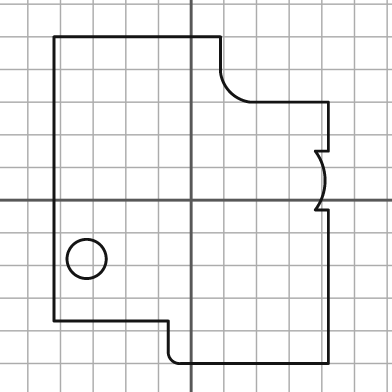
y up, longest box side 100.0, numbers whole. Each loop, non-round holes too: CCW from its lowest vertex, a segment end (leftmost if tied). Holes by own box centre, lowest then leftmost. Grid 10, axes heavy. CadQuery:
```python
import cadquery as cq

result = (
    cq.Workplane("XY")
    .moveTo(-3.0, -50.0)
    .lineTo(42.0, -50.0)
    .lineTo(42.0, -3.0)
    .lineTo(38.0, -3.0)
    .threePointArc((41.0, 6.0), (38.0, 15.0))
    .lineTo(42.0, 15.0)
    .lineTo(42.0, 30.0)
    .lineTo(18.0, 30.0)
    .threePointArc((12.0, 33.0), (9.0, 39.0))
    .lineTo(9.0, 50.0)
    .lineTo(-42.0, 50.0)
    .lineTo(-42.0, -37.0)
    .lineTo(-7.0, -37.0)
    .lineTo(-7.0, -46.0)
    .threePointArc((-6.0, -49.0), (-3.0, -50.0))
    .close()
    .moveTo(-32.0, -18.0)
    .circle(6.0)
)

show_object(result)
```